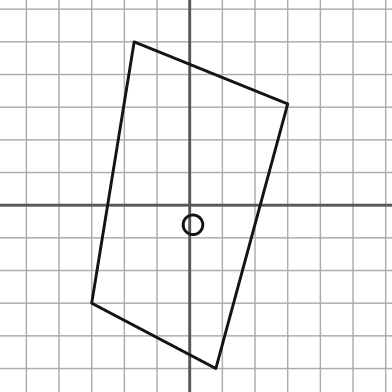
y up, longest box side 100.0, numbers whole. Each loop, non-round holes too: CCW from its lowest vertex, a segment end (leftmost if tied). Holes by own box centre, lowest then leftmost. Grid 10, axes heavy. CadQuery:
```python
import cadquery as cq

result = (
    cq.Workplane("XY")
    .moveTo(8.0, -50.0)
    .lineTo(30.0, 31.0)
    .lineTo(-17.0, 50.0)
    .lineTo(-30.0, -30.0)
    .close()
    .moveTo(1.0, -6.0)
    .circle(3.0)
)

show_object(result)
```